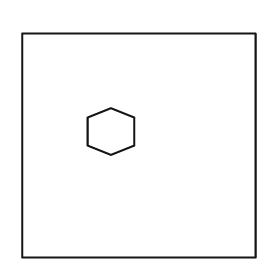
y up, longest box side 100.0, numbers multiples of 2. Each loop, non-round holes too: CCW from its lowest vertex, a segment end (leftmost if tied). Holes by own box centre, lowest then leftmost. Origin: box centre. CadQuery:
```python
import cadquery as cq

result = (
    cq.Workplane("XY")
    .moveTo(-50.0, -48.0)
    .lineTo(50.0, -48.0)
    .lineTo(50.0, 48.0)
    .lineTo(-50.0, 48.0)
    .close()
    .moveTo(-12.0, -4.0)
    .lineTo(-2.0, 0.0)
    .lineTo(-2.0, 12.0)
    .lineTo(-12.0, 16.0)
    .lineTo(-22.0, 12.0)
    .lineTo(-22.0, 0.0)
    .close()
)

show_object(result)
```